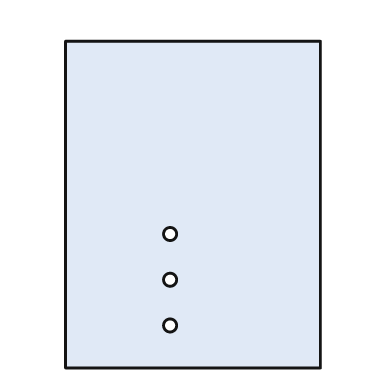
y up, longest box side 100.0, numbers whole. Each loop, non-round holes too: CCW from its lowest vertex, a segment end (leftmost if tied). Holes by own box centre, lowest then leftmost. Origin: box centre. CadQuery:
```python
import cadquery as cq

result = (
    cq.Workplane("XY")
    .moveTo(-39.0, -50.0)
    .lineTo(39.0, -50.0)
    .lineTo(39.0, 50.0)
    .lineTo(-39.0, 50.0)
    .close()
    .moveTo(-7.0, -37.0)
    .circle(2.0)
    .moveTo(-7.0, -23.0)
    .circle(2.0)
    .moveTo(-7.0, -9.0)
    .circle(2.0)
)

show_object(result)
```